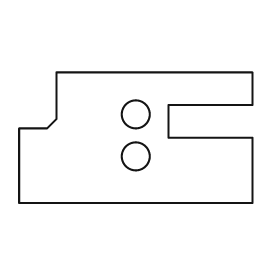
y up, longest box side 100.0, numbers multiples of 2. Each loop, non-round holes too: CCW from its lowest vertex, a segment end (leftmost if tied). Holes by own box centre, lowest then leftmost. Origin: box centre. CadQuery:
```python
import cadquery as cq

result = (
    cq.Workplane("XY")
    .moveTo(-50.0, -28.0)
    .lineTo(50.0, -28.0)
    .lineTo(50.0, 0.0)
    .lineTo(14.0, 0.0)
    .lineTo(14.0, 14.0)
    .lineTo(50.0, 14.0)
    .lineTo(50.0, 28.0)
    .lineTo(-34.0, 28.0)
    .lineTo(-34.0, 8.0)
    .lineTo(-38.0, 4.0)
    .lineTo(-50.0, 4.0)
    .close()
    .moveTo(0.0, -8.0)
    .circle(6.0)
    .moveTo(0.0, 10.0)
    .circle(6.0)
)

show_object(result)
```